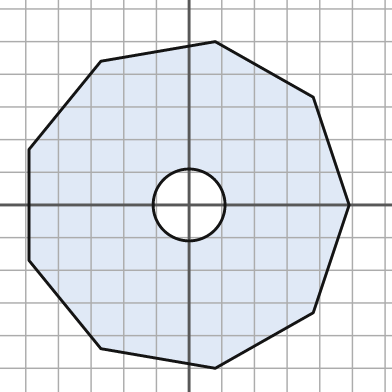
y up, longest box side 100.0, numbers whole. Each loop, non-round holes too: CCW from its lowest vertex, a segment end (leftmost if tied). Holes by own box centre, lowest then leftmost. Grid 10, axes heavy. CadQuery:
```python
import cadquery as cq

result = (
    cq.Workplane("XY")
    .moveTo(8.0, -50.0)
    .lineTo(38.0, -33.0)
    .lineTo(49.0, 0.0)
    .lineTo(38.0, 33.0)
    .lineTo(8.0, 50.0)
    .lineTo(-27.0, 44.0)
    .lineTo(-49.0, 17.0)
    .lineTo(-49.0, -17.0)
    .lineTo(-27.0, -44.0)
    .close()
    .moveTo(0.0, 0.0)
    .circle(11.0)
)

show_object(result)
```